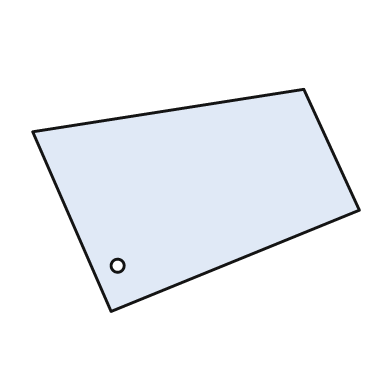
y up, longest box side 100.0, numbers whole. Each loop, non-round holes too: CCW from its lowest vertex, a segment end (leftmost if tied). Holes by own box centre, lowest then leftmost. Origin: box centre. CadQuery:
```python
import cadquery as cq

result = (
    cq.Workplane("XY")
    .moveTo(-26.0, -34.0)
    .lineTo(50.0, -3.0)
    .lineTo(33.0, 34.0)
    .lineTo(-50.0, 21.0)
    .close()
    .moveTo(-24.0, -20.0)
    .circle(2.0)
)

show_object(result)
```